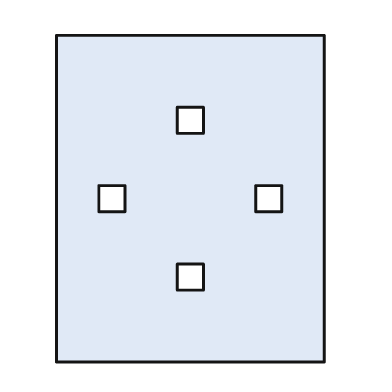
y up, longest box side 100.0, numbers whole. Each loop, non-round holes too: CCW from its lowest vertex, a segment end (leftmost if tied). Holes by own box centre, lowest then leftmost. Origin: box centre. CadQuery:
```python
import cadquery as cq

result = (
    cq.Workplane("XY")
    .moveTo(-41.0, -50.0)
    .lineTo(41.0, -50.0)
    .lineTo(41.0, 50.0)
    .lineTo(-41.0, 50.0)
    .close()
    .moveTo(-4.0, -28.0)
    .lineTo(4.0, -28.0)
    .lineTo(4.0, -20.0)
    .lineTo(-4.0, -20.0)
    .close()
    .moveTo(-28.0, -4.0)
    .lineTo(-20.0, -4.0)
    .lineTo(-20.0, 4.0)
    .lineTo(-28.0, 4.0)
    .close()
    .moveTo(20.0, -4.0)
    .lineTo(28.0, -4.0)
    .lineTo(28.0, 4.0)
    .lineTo(20.0, 4.0)
    .close()
    .moveTo(-4.0, 20.0)
    .lineTo(4.0, 20.0)
    .lineTo(4.0, 28.0)
    .lineTo(-4.0, 28.0)
    .close()
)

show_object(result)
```